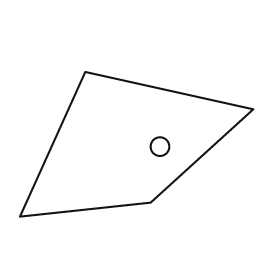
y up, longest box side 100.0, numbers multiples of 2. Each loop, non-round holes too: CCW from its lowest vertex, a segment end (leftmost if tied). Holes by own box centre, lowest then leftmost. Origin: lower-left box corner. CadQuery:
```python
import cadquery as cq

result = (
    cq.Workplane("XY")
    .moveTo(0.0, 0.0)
    .lineTo(56.0, 6.0)
    .lineTo(100.0, 46.0)
    .lineTo(28.0, 62.0)
    .close()
    .moveTo(60.0, 30.0)
    .circle(4.0)
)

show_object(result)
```